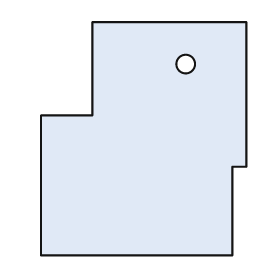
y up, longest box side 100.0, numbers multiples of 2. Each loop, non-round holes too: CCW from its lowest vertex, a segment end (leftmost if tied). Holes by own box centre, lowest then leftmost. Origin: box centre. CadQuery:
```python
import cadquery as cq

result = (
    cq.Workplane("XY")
    .moveTo(-44.0, -50.0)
    .lineTo(38.0, -50.0)
    .lineTo(38.0, -12.0)
    .lineTo(44.0, -12.0)
    .lineTo(44.0, 50.0)
    .lineTo(-22.0, 50.0)
    .lineTo(-22.0, 10.0)
    .lineTo(-44.0, 10.0)
    .close()
    .moveTo(18.0, 32.0)
    .circle(4.0)
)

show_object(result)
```